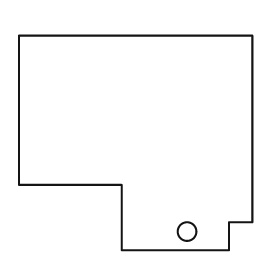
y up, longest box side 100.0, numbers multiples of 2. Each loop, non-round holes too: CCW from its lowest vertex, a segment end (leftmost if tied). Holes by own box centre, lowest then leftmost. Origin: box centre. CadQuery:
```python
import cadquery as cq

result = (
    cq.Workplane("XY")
    .moveTo(-6.0, -46.0)
    .lineTo(40.0, -46.0)
    .lineTo(40.0, -34.0)
    .lineTo(50.0, -34.0)
    .lineTo(50.0, 46.0)
    .lineTo(-50.0, 46.0)
    .lineTo(-50.0, -18.0)
    .lineTo(-6.0, -18.0)
    .close()
    .moveTo(22.0, -38.0)
    .circle(4.0)
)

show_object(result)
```